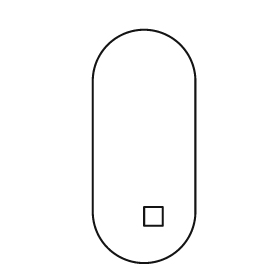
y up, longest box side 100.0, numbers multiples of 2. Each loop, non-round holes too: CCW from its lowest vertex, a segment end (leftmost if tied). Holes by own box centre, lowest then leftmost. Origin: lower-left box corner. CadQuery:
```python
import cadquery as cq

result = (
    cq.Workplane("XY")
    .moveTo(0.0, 22.0)
    .threePointArc((22.0, 0.0), (44.0, 22.0))
    .lineTo(44.0, 78.0)
    .threePointArc((22.0, 100.0), (0.0, 78.0))
    .close()
    .moveTo(22.0, 16.0)
    .lineTo(30.0, 16.0)
    .lineTo(30.0, 24.0)
    .lineTo(22.0, 24.0)
    .close()
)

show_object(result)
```